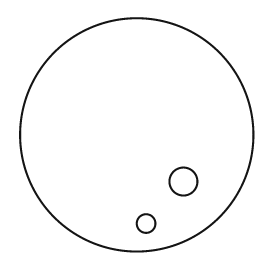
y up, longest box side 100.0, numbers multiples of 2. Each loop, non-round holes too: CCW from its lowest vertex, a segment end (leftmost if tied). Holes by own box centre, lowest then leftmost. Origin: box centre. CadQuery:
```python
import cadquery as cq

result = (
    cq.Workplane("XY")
    .moveTo(0.0, 0.0)
    .circle(50.0)
    .moveTo(4.0, -38.0)
    .circle(4.0)
    .moveTo(20.0, -20.0)
    .circle(6.0)
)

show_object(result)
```